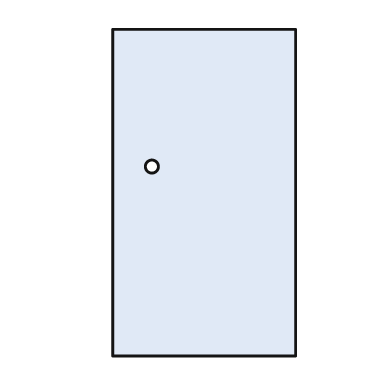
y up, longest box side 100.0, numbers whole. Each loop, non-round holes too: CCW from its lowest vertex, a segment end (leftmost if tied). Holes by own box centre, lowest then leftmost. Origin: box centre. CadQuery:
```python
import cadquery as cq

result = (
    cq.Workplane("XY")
    .moveTo(-28.0, -50.0)
    .lineTo(28.0, -50.0)
    .lineTo(28.0, 50.0)
    .lineTo(-28.0, 50.0)
    .close()
    .moveTo(-16.0, 8.0)
    .circle(2.0)
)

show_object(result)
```